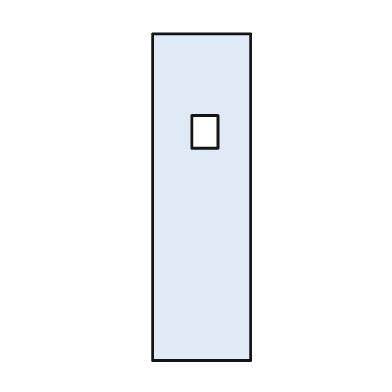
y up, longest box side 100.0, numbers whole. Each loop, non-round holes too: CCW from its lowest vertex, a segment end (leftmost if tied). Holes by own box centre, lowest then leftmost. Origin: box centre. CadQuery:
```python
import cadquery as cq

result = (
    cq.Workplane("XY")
    .moveTo(-15.0, -50.0)
    .lineTo(15.0, -50.0)
    .lineTo(15.0, 50.0)
    .lineTo(-15.0, 50.0)
    .close()
    .moveTo(-3.0, 15.0)
    .lineTo(5.0, 15.0)
    .lineTo(5.0, 25.0)
    .lineTo(-3.0, 25.0)
    .close()
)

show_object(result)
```